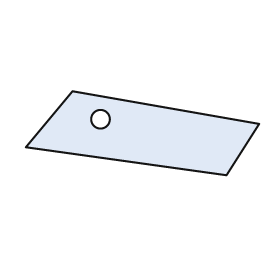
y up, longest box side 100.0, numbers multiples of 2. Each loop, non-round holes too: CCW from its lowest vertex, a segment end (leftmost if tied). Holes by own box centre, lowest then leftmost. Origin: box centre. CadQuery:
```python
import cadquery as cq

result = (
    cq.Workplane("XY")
    .moveTo(36.0, -18.0)
    .lineTo(50.0, 4.0)
    .lineTo(-30.0, 18.0)
    .lineTo(-50.0, -6.0)
    .close()
    .moveTo(-18.0, 6.0)
    .circle(4.0)
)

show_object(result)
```